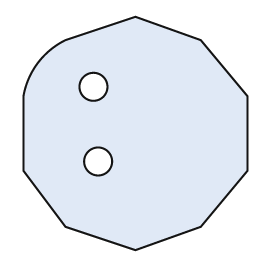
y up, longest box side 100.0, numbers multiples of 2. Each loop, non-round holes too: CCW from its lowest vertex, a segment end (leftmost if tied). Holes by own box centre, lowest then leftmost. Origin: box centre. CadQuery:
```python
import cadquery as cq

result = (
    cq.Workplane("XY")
    .moveTo(0.0, -50.0)
    .lineTo(28.0, -40.0)
    .lineTo(48.0, -16.0)
    .lineTo(48.0, 16.0)
    .lineTo(28.0, 40.0)
    .lineTo(0.0, 50.0)
    .lineTo(-30.0, 40.0)
    .threePointArc((-42.0, 30.0), (-48.0, 16.0))
    .lineTo(-48.0, -16.0)
    .lineTo(-30.0, -40.0)
    .close()
    .moveTo(-16.0, -12.0)
    .circle(6.0)
    .moveTo(-18.0, 20.0)
    .circle(6.0)
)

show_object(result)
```